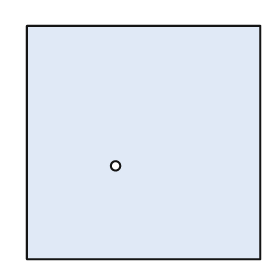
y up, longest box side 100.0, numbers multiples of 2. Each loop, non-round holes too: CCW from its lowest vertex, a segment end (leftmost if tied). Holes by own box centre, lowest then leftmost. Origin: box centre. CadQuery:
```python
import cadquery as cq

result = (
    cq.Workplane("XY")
    .moveTo(-50.0, -50.0)
    .lineTo(50.0, -50.0)
    .lineTo(50.0, 50.0)
    .lineTo(-50.0, 50.0)
    .close()
    .moveTo(-12.0, -10.0)
    .circle(2.0)
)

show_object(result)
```